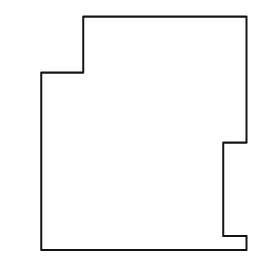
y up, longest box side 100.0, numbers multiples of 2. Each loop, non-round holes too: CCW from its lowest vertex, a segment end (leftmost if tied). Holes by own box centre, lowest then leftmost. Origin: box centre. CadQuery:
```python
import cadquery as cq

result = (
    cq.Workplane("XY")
    .moveTo(-44.0, -50.0)
    .lineTo(44.0, -50.0)
    .lineTo(44.0, -44.0)
    .lineTo(34.0, -44.0)
    .lineTo(34.0, -4.0)
    .lineTo(44.0, -4.0)
    .lineTo(44.0, 50.0)
    .lineTo(-26.0, 50.0)
    .lineTo(-26.0, 26.0)
    .lineTo(-44.0, 26.0)
    .close()
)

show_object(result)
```